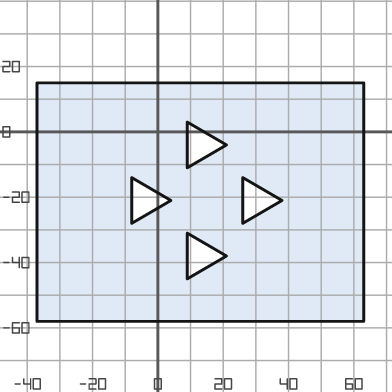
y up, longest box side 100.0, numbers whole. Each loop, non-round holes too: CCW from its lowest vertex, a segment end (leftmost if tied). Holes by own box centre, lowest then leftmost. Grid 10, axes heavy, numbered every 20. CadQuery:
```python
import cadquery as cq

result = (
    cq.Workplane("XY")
    .moveTo(-37.0, -58.0)
    .lineTo(63.0, -58.0)
    .lineTo(63.0, 15.0)
    .lineTo(-37.0, 15.0)
    .close()
    .moveTo(9.0, -45.0)
    .lineTo(21.0, -38.0)
    .lineTo(9.0, -31.0)
    .close()
    .moveTo(-8.0, -28.0)
    .lineTo(4.0, -21.0)
    .lineTo(-8.0, -14.0)
    .close()
    .moveTo(26.0, -28.0)
    .lineTo(38.0, -21.0)
    .lineTo(26.0, -14.0)
    .close()
    .moveTo(9.0, -11.0)
    .lineTo(21.0, -4.0)
    .lineTo(9.0, 3.0)
    .close()
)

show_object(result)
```